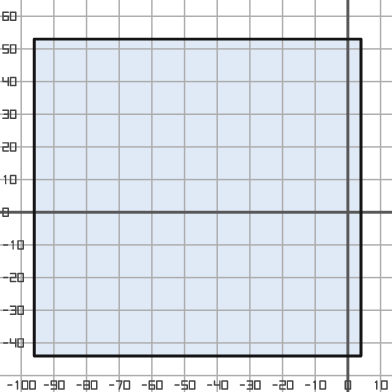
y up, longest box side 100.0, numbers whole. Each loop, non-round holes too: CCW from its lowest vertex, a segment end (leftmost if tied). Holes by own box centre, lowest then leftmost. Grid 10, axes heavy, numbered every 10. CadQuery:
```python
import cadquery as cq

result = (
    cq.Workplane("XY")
    .moveTo(-96.0, -44.0)
    .lineTo(4.0, -44.0)
    .lineTo(4.0, 53.0)
    .lineTo(-96.0, 53.0)
    .close()
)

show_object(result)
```